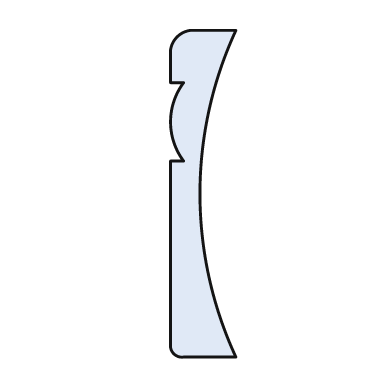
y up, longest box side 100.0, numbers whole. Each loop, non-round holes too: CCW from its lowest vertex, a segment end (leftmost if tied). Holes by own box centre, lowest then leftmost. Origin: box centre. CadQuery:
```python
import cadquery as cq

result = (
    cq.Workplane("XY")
    .moveTo(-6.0, -50.0)
    .lineTo(10.0, -50.0)
    .threePointArc((-1.0, 0.0), (10.0, 50.0))
    .lineTo(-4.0, 50.0)
    .threePointArc((-8.0, 48.0), (-10.0, 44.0))
    .lineTo(-10.0, 34.0)
    .lineTo(-6.0, 34.0)
    .threePointArc((-10.0, 22.0), (-6.0, 10.0))
    .lineTo(-10.0, 10.0)
    .lineTo(-10.0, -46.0)
    .threePointArc((-9.0, -49.0), (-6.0, -50.0))
    .close()
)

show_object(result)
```